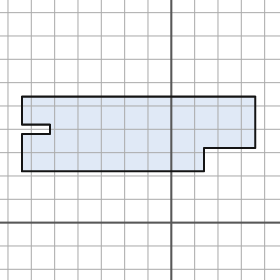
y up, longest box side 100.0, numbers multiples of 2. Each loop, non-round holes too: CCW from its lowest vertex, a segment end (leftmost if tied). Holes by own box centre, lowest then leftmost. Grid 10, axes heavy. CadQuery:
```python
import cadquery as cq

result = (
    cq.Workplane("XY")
    .moveTo(-64.0, 22.0)
    .lineTo(14.0, 22.0)
    .lineTo(14.0, 32.0)
    .lineTo(36.0, 32.0)
    .lineTo(36.0, 54.0)
    .lineTo(-64.0, 54.0)
    .lineTo(-64.0, 42.0)
    .lineTo(-52.0, 42.0)
    .lineTo(-52.0, 38.0)
    .lineTo(-64.0, 38.0)
    .close()
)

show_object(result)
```